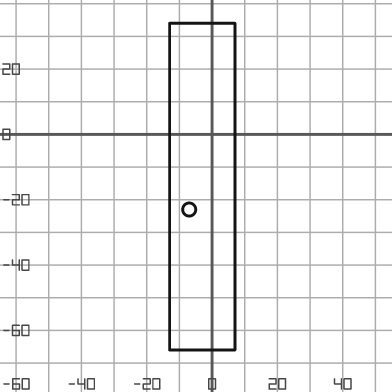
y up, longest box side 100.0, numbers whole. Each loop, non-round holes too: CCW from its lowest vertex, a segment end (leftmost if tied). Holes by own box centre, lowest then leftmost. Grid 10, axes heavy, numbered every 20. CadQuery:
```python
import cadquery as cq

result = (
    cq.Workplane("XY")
    .moveTo(-13.0, -66.0)
    .lineTo(7.0, -66.0)
    .lineTo(7.0, 34.0)
    .lineTo(-13.0, 34.0)
    .close()
    .moveTo(-7.0, -23.0)
    .circle(2.0)
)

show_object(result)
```